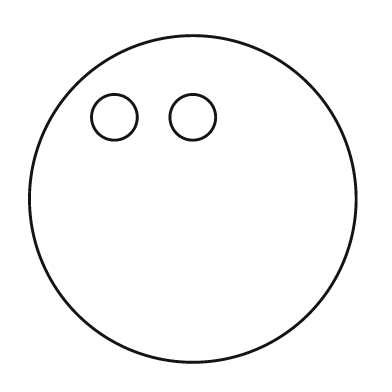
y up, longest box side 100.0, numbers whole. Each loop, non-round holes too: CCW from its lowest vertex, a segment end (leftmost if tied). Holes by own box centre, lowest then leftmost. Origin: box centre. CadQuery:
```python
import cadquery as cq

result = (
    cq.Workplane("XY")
    .moveTo(0.0, 0.0)
    .circle(50.0)
    .moveTo(-24.0, 25.0)
    .circle(7.0)
    .moveTo(0.0, 25.0)
    .circle(7.0)
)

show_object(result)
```